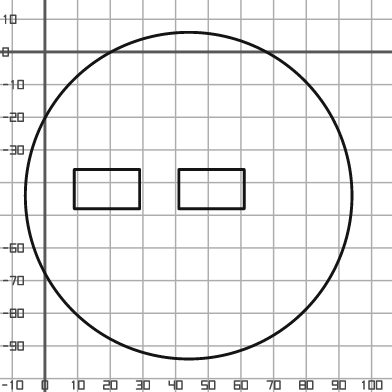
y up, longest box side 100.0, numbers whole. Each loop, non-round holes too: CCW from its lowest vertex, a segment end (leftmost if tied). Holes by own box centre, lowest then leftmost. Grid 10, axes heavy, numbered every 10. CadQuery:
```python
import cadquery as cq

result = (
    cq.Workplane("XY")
    .moveTo(44.0, -44.0)
    .circle(50.0)
    .moveTo(9.0, -48.0)
    .lineTo(29.0, -48.0)
    .lineTo(29.0, -36.0)
    .lineTo(9.0, -36.0)
    .close()
    .moveTo(41.0, -48.0)
    .lineTo(61.0, -48.0)
    .lineTo(61.0, -36.0)
    .lineTo(41.0, -36.0)
    .close()
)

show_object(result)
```